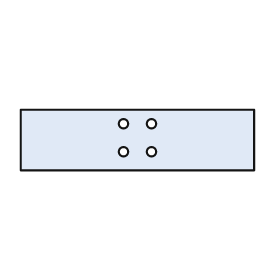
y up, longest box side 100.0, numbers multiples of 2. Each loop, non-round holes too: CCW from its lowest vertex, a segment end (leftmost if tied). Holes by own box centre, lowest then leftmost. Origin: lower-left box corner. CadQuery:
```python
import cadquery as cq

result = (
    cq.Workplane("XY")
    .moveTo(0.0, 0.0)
    .lineTo(100.0, 0.0)
    .lineTo(100.0, 26.0)
    .lineTo(0.0, 26.0)
    .close()
    .moveTo(44.0, 8.0)
    .circle(2.0)
    .moveTo(56.0, 8.0)
    .circle(2.0)
    .moveTo(44.0, 20.0)
    .circle(2.0)
    .moveTo(56.0, 20.0)
    .circle(2.0)
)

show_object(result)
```